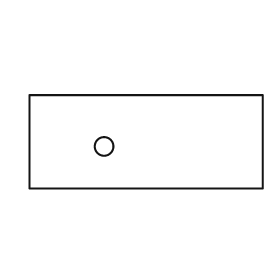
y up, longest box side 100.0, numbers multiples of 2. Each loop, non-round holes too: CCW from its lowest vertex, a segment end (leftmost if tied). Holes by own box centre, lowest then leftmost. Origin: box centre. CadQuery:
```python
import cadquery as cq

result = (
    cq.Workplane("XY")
    .moveTo(-50.0, -20.0)
    .lineTo(50.0, -20.0)
    .lineTo(50.0, 20.0)
    .lineTo(-50.0, 20.0)
    .close()
    .moveTo(-18.0, -2.0)
    .circle(4.0)
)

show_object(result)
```